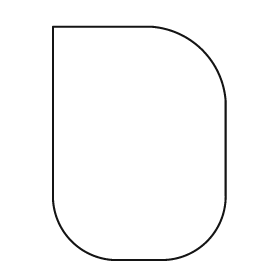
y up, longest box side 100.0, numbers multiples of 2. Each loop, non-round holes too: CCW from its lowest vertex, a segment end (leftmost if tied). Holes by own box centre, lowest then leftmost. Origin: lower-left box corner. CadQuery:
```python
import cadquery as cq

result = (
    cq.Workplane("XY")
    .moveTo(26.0, 0.0)
    .lineTo(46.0, 0.0)
    .threePointArc((66.0, 8.0), (74.0, 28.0))
    .lineTo(74.0, 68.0)
    .threePointArc((64.0, 90.0), (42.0, 100.0))
    .lineTo(0.0, 100.0)
    .lineTo(0.0, 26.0)
    .threePointArc((8.0, 8.0), (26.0, 0.0))
    .close()
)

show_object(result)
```